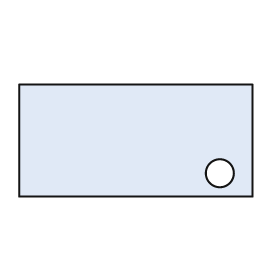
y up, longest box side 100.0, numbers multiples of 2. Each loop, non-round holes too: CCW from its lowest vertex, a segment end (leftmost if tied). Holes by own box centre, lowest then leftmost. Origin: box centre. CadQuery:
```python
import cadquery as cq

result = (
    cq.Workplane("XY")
    .moveTo(-50.0, -24.0)
    .lineTo(50.0, -24.0)
    .lineTo(50.0, 24.0)
    .lineTo(-50.0, 24.0)
    .close()
    .moveTo(36.0, -14.0)
    .circle(6.0)
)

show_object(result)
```